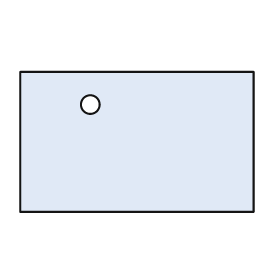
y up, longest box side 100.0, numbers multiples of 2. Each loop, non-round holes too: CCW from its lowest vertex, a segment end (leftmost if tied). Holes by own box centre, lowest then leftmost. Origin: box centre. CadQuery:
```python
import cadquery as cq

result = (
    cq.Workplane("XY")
    .moveTo(-50.0, -30.0)
    .lineTo(50.0, -30.0)
    .lineTo(50.0, 30.0)
    .lineTo(-50.0, 30.0)
    .close()
    .moveTo(-20.0, 16.0)
    .circle(4.0)
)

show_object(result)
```